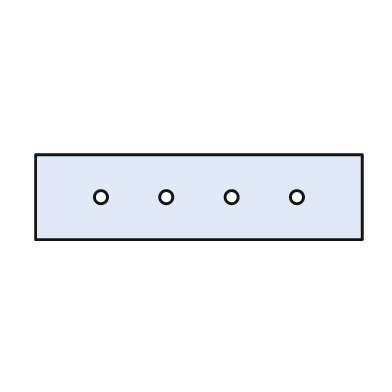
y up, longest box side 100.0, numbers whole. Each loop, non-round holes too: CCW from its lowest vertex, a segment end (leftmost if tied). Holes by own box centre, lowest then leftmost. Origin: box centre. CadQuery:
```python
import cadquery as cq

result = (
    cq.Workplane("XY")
    .moveTo(-50.0, -13.0)
    .lineTo(50.0, -13.0)
    .lineTo(50.0, 13.0)
    .lineTo(-50.0, 13.0)
    .close()
    .moveTo(-30.0, 0.0)
    .circle(2.0)
    .moveTo(-10.0, 0.0)
    .circle(2.0)
    .moveTo(10.0, 0.0)
    .circle(2.0)
    .moveTo(30.0, 0.0)
    .circle(2.0)
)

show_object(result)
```